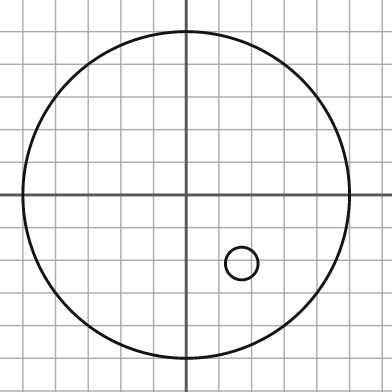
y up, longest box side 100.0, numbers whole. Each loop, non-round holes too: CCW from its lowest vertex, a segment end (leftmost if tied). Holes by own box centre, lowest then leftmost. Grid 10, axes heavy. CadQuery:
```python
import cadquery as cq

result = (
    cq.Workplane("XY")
    .moveTo(0.0, 0.0)
    .circle(50.0)
    .moveTo(17.0, -21.0)
    .circle(5.0)
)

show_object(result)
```